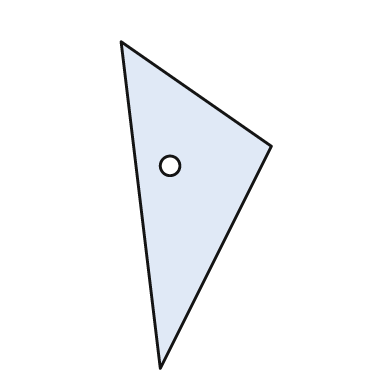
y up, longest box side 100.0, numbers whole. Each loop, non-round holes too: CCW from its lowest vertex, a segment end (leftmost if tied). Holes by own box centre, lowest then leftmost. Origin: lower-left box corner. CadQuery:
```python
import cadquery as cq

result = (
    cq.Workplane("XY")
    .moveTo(12.0, 0.0)
    .lineTo(46.0, 68.0)
    .lineTo(0.0, 100.0)
    .close()
    .moveTo(15.0, 62.0)
    .circle(3.0)
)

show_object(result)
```